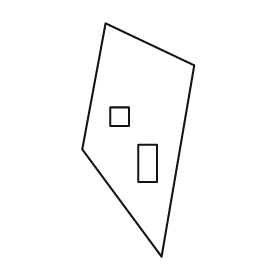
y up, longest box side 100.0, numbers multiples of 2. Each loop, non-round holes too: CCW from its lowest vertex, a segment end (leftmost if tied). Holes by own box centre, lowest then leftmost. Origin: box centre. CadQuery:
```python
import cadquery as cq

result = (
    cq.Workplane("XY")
    .moveTo(10.0, -50.0)
    .lineTo(24.0, 32.0)
    .lineTo(-14.0, 50.0)
    .lineTo(-24.0, -4.0)
    .close()
    .moveTo(0.0, -18.0)
    .lineTo(8.0, -18.0)
    .lineTo(8.0, -2.0)
    .lineTo(0.0, -2.0)
    .close()
    .moveTo(-12.0, 6.0)
    .lineTo(-4.0, 6.0)
    .lineTo(-4.0, 14.0)
    .lineTo(-12.0, 14.0)
    .close()
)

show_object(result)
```